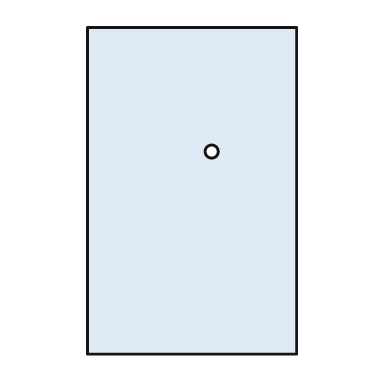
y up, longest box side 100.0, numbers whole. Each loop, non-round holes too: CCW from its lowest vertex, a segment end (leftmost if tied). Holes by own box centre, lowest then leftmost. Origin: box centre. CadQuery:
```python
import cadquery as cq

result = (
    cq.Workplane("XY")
    .moveTo(-32.0, -50.0)
    .lineTo(32.0, -50.0)
    .lineTo(32.0, 50.0)
    .lineTo(-32.0, 50.0)
    .close()
    .moveTo(6.0, 12.0)
    .circle(2.0)
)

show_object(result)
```